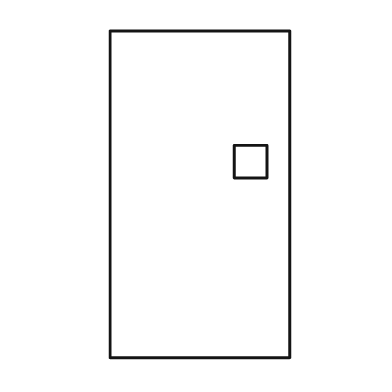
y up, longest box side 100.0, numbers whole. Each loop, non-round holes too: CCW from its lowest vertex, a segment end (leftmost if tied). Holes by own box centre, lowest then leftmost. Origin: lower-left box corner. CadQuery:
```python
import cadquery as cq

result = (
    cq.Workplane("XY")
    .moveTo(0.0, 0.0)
    .lineTo(55.0, 0.0)
    .lineTo(55.0, 100.0)
    .lineTo(0.0, 100.0)
    .close()
    .moveTo(38.0, 55.0)
    .lineTo(48.0, 55.0)
    .lineTo(48.0, 65.0)
    .lineTo(38.0, 65.0)
    .close()
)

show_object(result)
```